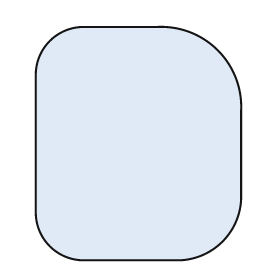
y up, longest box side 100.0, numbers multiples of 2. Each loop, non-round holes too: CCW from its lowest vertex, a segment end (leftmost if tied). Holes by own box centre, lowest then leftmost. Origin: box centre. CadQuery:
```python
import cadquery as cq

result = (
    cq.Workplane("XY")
    .moveTo(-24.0, -50.0)
    .lineTo(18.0, -50.0)
    .threePointArc((36.0, -42.0), (44.0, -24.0))
    .lineTo(44.0, 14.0)
    .threePointArc((34.0, 40.0), (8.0, 50.0))
    .lineTo(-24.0, 50.0)
    .threePointArc((-38.0, 44.0), (-44.0, 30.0))
    .lineTo(-44.0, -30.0)
    .threePointArc((-38.0, -44.0), (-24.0, -50.0))
    .close()
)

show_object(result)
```